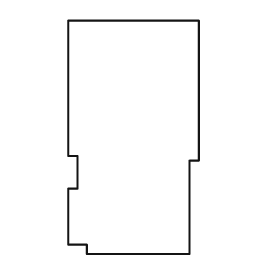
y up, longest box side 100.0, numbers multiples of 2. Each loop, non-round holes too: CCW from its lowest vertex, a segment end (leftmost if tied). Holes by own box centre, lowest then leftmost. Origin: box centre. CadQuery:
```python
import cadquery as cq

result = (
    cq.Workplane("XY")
    .moveTo(-20.0, -50.0)
    .lineTo(24.0, -50.0)
    .lineTo(24.0, -10.0)
    .lineTo(28.0, -10.0)
    .lineTo(28.0, 50.0)
    .lineTo(-28.0, 50.0)
    .lineTo(-28.0, -8.0)
    .lineTo(-24.0, -8.0)
    .lineTo(-24.0, -22.0)
    .lineTo(-28.0, -22.0)
    .lineTo(-28.0, -46.0)
    .lineTo(-20.0, -46.0)
    .close()
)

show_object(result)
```